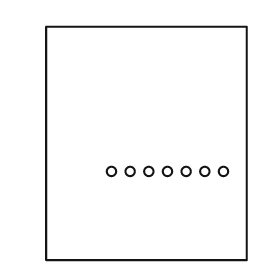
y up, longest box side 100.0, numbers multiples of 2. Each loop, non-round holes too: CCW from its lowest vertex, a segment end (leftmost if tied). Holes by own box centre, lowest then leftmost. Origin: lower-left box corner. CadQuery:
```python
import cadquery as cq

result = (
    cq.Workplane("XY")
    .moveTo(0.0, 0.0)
    .lineTo(86.0, 0.0)
    .lineTo(86.0, 100.0)
    .lineTo(0.0, 100.0)
    .close()
    .moveTo(28.0, 38.0)
    .circle(2.0)
    .moveTo(36.0, 38.0)
    .circle(2.0)
    .moveTo(44.0, 38.0)
    .circle(2.0)
    .moveTo(52.0, 38.0)
    .circle(2.0)
    .moveTo(60.0, 38.0)
    .circle(2.0)
    .moveTo(68.0, 38.0)
    .circle(2.0)
    .moveTo(76.0, 38.0)
    .circle(2.0)
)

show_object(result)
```